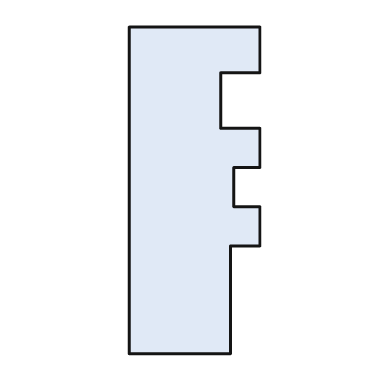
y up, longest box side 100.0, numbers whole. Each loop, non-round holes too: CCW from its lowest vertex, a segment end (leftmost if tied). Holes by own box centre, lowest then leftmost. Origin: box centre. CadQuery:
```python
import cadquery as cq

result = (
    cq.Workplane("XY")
    .moveTo(-20.0, -50.0)
    .lineTo(11.0, -50.0)
    .lineTo(11.0, -17.0)
    .lineTo(20.0, -17.0)
    .lineTo(20.0, -5.0)
    .lineTo(12.0, -5.0)
    .lineTo(12.0, 7.0)
    .lineTo(20.0, 7.0)
    .lineTo(20.0, 19.0)
    .lineTo(8.0, 19.0)
    .lineTo(8.0, 36.0)
    .lineTo(20.0, 36.0)
    .lineTo(20.0, 50.0)
    .lineTo(-20.0, 50.0)
    .close()
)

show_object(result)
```